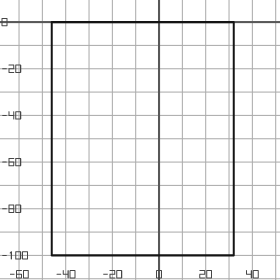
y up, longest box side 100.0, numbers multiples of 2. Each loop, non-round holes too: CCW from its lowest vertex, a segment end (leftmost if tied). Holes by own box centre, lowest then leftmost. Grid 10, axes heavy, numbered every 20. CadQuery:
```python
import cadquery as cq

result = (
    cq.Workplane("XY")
    .moveTo(-46.0, -100.0)
    .lineTo(32.0, -100.0)
    .lineTo(32.0, 0.0)
    .lineTo(-46.0, 0.0)
    .close()
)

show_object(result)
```